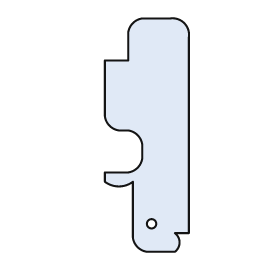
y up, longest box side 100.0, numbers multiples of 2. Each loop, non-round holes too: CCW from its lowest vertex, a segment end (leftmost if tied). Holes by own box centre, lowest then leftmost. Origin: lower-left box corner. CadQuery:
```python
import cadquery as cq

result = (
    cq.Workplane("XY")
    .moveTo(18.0, 0.0)
    .lineTo(30.0, 0.0)
    .threePointArc((32.0, 4.0), (30.0, 8.0))
    .lineTo(36.0, 8.0)
    .lineTo(36.0, 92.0)
    .threePointArc((34.0, 98.0), (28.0, 100.0))
    .lineTo(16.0, 100.0)
    .threePointArc((12.0, 98.0), (10.0, 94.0))
    .lineTo(10.0, 82.0)
    .lineTo(0.0, 82.0)
    .lineTo(0.0, 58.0)
    .threePointArc((2.0, 54.0), (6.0, 52.0))
    .lineTo(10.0, 52.0)
    .threePointArc((14.0, 50.0), (16.0, 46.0))
    .lineTo(16.0, 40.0)
    .threePointArc((14.0, 36.0), (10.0, 34.0))
    .lineTo(0.0, 34.0)
    .lineTo(0.0, 30.0)
    .threePointArc((6.0, 28.0), (12.0, 30.0))
    .lineTo(12.0, 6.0)
    .threePointArc((14.0, 2.0), (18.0, 0.0))
    .close()
    .moveTo(20.0, 12.0)
    .circle(2.0)
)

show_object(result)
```